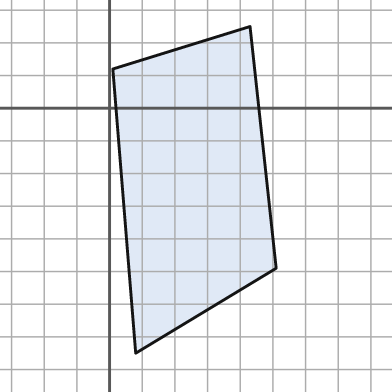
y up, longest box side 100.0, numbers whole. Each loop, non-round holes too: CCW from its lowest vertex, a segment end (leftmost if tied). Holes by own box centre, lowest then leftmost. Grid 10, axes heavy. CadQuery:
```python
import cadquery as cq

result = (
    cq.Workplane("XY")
    .moveTo(8.0, -75.0)
    .lineTo(51.0, -49.0)
    .lineTo(43.0, 25.0)
    .lineTo(1.0, 12.0)
    .close()
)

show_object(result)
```